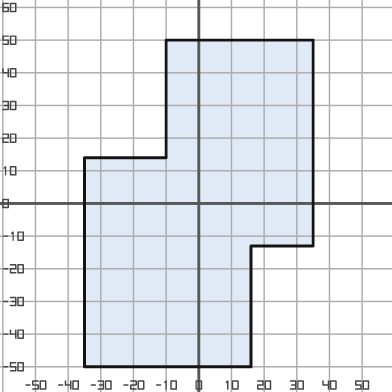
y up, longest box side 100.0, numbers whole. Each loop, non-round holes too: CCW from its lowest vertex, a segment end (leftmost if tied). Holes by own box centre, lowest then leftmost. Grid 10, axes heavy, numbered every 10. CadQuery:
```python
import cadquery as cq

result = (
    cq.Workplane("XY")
    .moveTo(-35.0, -50.0)
    .lineTo(16.0, -50.0)
    .lineTo(16.0, -13.0)
    .lineTo(35.0, -13.0)
    .lineTo(35.0, 50.0)
    .lineTo(-10.0, 50.0)
    .lineTo(-10.0, 14.0)
    .lineTo(-35.0, 14.0)
    .close()
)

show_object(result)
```